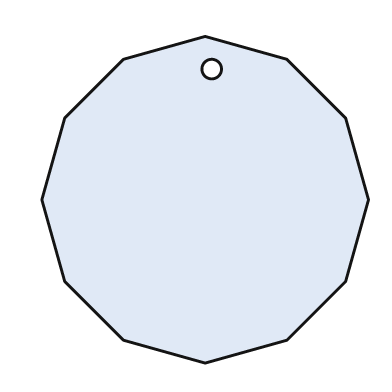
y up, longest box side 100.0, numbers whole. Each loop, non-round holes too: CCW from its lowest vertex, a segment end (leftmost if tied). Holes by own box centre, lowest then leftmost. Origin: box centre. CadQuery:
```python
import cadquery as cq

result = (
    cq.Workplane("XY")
    .moveTo(0.0, -50.0)
    .lineTo(25.0, -43.0)
    .lineTo(43.0, -25.0)
    .lineTo(50.0, 0.0)
    .lineTo(43.0, 25.0)
    .lineTo(25.0, 43.0)
    .lineTo(0.0, 50.0)
    .lineTo(-25.0, 43.0)
    .lineTo(-43.0, 25.0)
    .lineTo(-50.0, 0.0)
    .lineTo(-43.0, -25.0)
    .lineTo(-25.0, -43.0)
    .close()
    .moveTo(2.0, 40.0)
    .circle(3.0)
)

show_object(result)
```